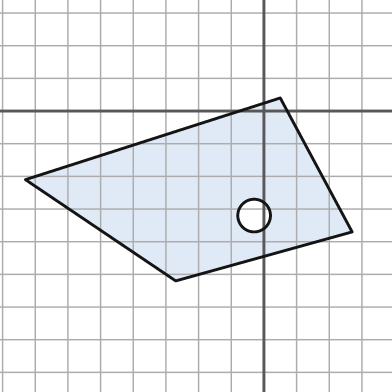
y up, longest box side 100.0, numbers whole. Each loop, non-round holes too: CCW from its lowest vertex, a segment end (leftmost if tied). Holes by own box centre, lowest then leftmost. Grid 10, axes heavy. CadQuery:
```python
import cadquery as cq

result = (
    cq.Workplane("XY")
    .moveTo(-27.0, -52.0)
    .lineTo(27.0, -37.0)
    .lineTo(5.0, 4.0)
    .lineTo(-73.0, -21.0)
    .close()
    .moveTo(-3.0, -32.0)
    .circle(5.0)
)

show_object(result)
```